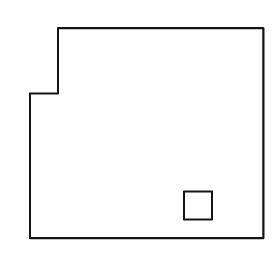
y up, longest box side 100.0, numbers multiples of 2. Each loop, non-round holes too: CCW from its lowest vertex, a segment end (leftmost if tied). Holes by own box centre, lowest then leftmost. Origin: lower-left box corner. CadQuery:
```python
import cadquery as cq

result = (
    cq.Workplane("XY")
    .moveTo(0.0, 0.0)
    .lineTo(100.0, 0.0)
    .lineTo(100.0, 90.0)
    .lineTo(12.0, 90.0)
    .lineTo(12.0, 62.0)
    .lineTo(0.0, 62.0)
    .close()
    .moveTo(66.0, 8.0)
    .lineTo(78.0, 8.0)
    .lineTo(78.0, 20.0)
    .lineTo(66.0, 20.0)
    .close()
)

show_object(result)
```